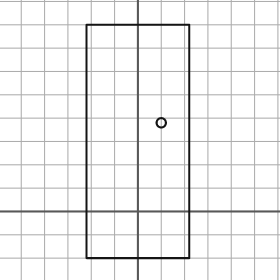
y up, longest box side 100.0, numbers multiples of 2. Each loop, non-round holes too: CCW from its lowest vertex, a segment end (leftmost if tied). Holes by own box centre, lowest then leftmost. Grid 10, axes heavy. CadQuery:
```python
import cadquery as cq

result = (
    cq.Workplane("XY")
    .moveTo(-22.0, -20.0)
    .lineTo(22.0, -20.0)
    .lineTo(22.0, 80.0)
    .lineTo(-22.0, 80.0)
    .close()
    .moveTo(10.0, 38.0)
    .circle(2.0)
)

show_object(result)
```